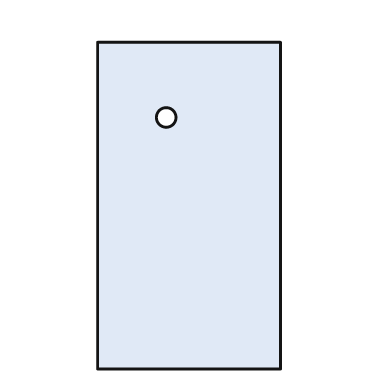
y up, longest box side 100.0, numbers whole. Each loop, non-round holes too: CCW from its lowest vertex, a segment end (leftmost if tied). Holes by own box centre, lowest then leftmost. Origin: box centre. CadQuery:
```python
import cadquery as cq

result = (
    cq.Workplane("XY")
    .moveTo(-28.0, -50.0)
    .lineTo(28.0, -50.0)
    .lineTo(28.0, 50.0)
    .lineTo(-28.0, 50.0)
    .close()
    .moveTo(-7.0, 27.0)
    .circle(3.0)
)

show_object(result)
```